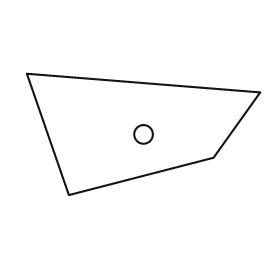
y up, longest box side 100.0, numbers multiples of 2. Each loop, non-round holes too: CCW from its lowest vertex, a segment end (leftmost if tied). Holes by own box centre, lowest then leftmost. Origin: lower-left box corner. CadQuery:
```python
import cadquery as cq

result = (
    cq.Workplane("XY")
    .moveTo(18.0, 0.0)
    .lineTo(80.0, 16.0)
    .lineTo(100.0, 44.0)
    .lineTo(0.0, 52.0)
    .close()
    .moveTo(50.0, 26.0)
    .circle(4.0)
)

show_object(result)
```